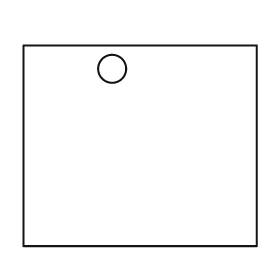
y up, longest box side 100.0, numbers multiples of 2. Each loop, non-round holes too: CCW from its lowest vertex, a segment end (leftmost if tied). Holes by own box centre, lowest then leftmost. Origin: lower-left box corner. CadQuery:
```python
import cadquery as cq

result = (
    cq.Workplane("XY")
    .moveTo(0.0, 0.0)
    .lineTo(100.0, 0.0)
    .lineTo(100.0, 86.0)
    .lineTo(0.0, 86.0)
    .close()
    .moveTo(38.0, 76.0)
    .circle(6.0)
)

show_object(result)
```